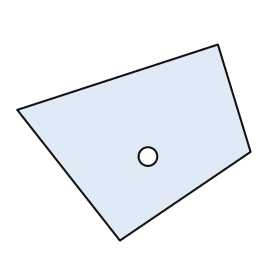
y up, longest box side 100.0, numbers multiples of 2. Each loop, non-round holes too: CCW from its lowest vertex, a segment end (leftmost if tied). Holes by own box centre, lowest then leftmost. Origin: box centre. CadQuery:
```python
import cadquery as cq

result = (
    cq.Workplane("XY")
    .moveTo(-6.0, -42.0)
    .lineTo(50.0, -4.0)
    .lineTo(36.0, 42.0)
    .lineTo(-50.0, 14.0)
    .close()
    .moveTo(6.0, -6.0)
    .circle(4.0)
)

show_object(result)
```